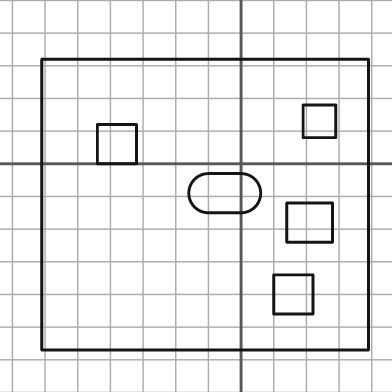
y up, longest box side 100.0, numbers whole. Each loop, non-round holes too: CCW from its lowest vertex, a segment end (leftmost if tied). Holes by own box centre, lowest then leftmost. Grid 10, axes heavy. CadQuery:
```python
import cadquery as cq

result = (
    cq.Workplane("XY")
    .moveTo(-61.0, -57.0)
    .lineTo(39.0, -57.0)
    .lineTo(39.0, 32.0)
    .lineTo(-61.0, 32.0)
    .close()
    .moveTo(10.0, -46.0)
    .lineTo(22.0, -46.0)
    .lineTo(22.0, -34.0)
    .lineTo(10.0, -34.0)
    .close()
    .moveTo(14.0, -24.0)
    .lineTo(28.0, -24.0)
    .lineTo(28.0, -12.0)
    .lineTo(14.0, -12.0)
    .close()
    .moveTo(-10.0, -15.0)
    .lineTo(0.0, -15.0)
    .threePointArc((6.0, -9.0), (0.0, -3.0))
    .lineTo(-10.0, -3.0)
    .threePointArc((-16.0, -9.0), (-10.0, -15.0))
    .close()
    .moveTo(-44.0, 0.0)
    .lineTo(-32.0, 0.0)
    .lineTo(-32.0, 12.0)
    .lineTo(-44.0, 12.0)
    .close()
    .moveTo(19.0, 8.0)
    .lineTo(29.0, 8.0)
    .lineTo(29.0, 18.0)
    .lineTo(19.0, 18.0)
    .close()
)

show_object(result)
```